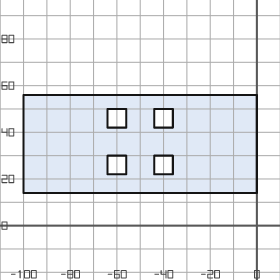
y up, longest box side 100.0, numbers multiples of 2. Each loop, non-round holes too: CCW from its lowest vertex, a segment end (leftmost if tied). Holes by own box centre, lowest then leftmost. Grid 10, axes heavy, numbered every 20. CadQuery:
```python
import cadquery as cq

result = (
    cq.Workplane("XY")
    .moveTo(-100.0, 14.0)
    .lineTo(0.0, 14.0)
    .lineTo(0.0, 56.0)
    .lineTo(-100.0, 56.0)
    .close()
    .moveTo(-64.0, 22.0)
    .lineTo(-56.0, 22.0)
    .lineTo(-56.0, 30.0)
    .lineTo(-64.0, 30.0)
    .close()
    .moveTo(-44.0, 22.0)
    .lineTo(-36.0, 22.0)
    .lineTo(-36.0, 30.0)
    .lineTo(-44.0, 30.0)
    .close()
    .moveTo(-64.0, 42.0)
    .lineTo(-56.0, 42.0)
    .lineTo(-56.0, 50.0)
    .lineTo(-64.0, 50.0)
    .close()
    .moveTo(-44.0, 42.0)
    .lineTo(-36.0, 42.0)
    .lineTo(-36.0, 50.0)
    .lineTo(-44.0, 50.0)
    .close()
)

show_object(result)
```